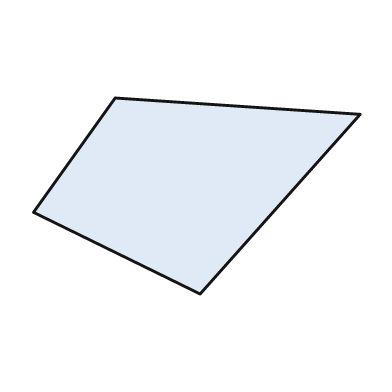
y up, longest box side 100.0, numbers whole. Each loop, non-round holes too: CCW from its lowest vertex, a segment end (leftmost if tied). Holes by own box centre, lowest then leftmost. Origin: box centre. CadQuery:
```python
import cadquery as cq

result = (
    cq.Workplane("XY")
    .moveTo(1.0, -30.0)
    .lineTo(50.0, 25.0)
    .lineTo(-25.0, 30.0)
    .lineTo(-50.0, -5.0)
    .close()
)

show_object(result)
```